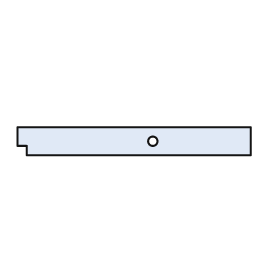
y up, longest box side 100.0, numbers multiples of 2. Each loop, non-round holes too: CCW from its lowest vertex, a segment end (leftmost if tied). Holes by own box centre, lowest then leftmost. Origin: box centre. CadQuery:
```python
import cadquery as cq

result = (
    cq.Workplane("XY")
    .moveTo(-46.0, -6.0)
    .lineTo(50.0, -6.0)
    .lineTo(50.0, 6.0)
    .lineTo(-50.0, 6.0)
    .lineTo(-50.0, -2.0)
    .lineTo(-46.0, -2.0)
    .close()
    .moveTo(8.0, 0.0)
    .circle(2.0)
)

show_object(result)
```